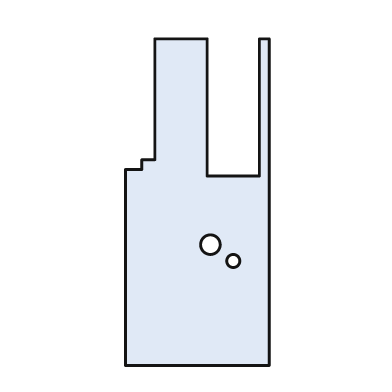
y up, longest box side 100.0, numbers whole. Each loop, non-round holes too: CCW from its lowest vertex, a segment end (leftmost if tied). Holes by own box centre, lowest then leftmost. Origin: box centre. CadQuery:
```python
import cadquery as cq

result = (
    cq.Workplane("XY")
    .moveTo(-22.0, -50.0)
    .lineTo(22.0, -50.0)
    .lineTo(22.0, 50.0)
    .lineTo(19.0, 50.0)
    .lineTo(19.0, 8.0)
    .lineTo(3.0, 8.0)
    .lineTo(3.0, 50.0)
    .lineTo(-13.0, 50.0)
    .lineTo(-13.0, 13.0)
    .lineTo(-17.0, 13.0)
    .lineTo(-17.0, 10.0)
    .lineTo(-22.0, 10.0)
    .close()
    .moveTo(11.0, -18.0)
    .circle(2.0)
    .moveTo(4.0, -13.0)
    .circle(3.0)
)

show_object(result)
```